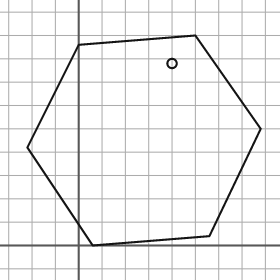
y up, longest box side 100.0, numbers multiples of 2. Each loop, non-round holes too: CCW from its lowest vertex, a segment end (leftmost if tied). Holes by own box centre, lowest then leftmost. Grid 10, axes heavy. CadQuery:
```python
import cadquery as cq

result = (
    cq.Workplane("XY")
    .moveTo(6.0, 0.0)
    .lineTo(56.0, 4.0)
    .lineTo(78.0, 50.0)
    .lineTo(50.0, 90.0)
    .lineTo(0.0, 86.0)
    .lineTo(-22.0, 42.0)
    .close()
    .moveTo(40.0, 78.0)
    .circle(2.0)
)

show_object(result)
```